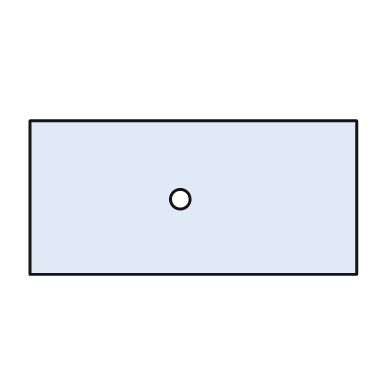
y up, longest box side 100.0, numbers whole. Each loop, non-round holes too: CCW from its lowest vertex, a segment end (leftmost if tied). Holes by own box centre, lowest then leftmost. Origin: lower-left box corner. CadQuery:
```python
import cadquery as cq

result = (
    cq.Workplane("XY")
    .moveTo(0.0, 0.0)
    .lineTo(100.0, 0.0)
    .lineTo(100.0, 47.0)
    .lineTo(0.0, 47.0)
    .close()
    .moveTo(46.0, 23.0)
    .circle(3.0)
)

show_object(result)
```